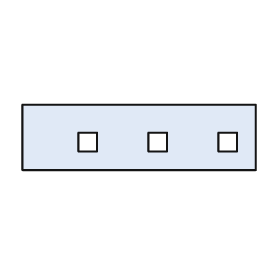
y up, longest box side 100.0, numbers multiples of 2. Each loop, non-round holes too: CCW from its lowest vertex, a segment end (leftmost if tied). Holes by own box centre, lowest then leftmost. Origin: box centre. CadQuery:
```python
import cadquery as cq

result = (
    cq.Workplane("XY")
    .moveTo(-50.0, -14.0)
    .lineTo(50.0, -14.0)
    .lineTo(50.0, 14.0)
    .lineTo(-50.0, 14.0)
    .close()
    .moveTo(-26.0, -6.0)
    .lineTo(-18.0, -6.0)
    .lineTo(-18.0, 2.0)
    .lineTo(-26.0, 2.0)
    .close()
    .moveTo(4.0, -6.0)
    .lineTo(12.0, -6.0)
    .lineTo(12.0, 2.0)
    .lineTo(4.0, 2.0)
    .close()
    .moveTo(34.0, -6.0)
    .lineTo(42.0, -6.0)
    .lineTo(42.0, 2.0)
    .lineTo(34.0, 2.0)
    .close()
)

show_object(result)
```